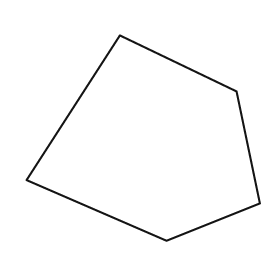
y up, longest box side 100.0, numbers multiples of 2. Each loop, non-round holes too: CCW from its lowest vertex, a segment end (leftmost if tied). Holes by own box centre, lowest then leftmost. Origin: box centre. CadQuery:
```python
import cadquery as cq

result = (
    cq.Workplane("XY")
    .moveTo(10.0, -44.0)
    .lineTo(50.0, -28.0)
    .lineTo(40.0, 20.0)
    .lineTo(-10.0, 44.0)
    .lineTo(-50.0, -18.0)
    .close()
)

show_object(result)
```